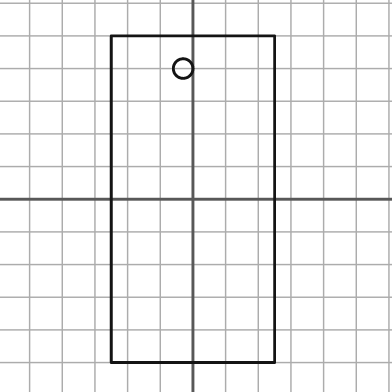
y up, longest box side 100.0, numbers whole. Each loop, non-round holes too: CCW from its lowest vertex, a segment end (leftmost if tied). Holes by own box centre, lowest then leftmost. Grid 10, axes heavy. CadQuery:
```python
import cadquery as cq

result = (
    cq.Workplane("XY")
    .moveTo(-25.0, -50.0)
    .lineTo(25.0, -50.0)
    .lineTo(25.0, 50.0)
    .lineTo(-25.0, 50.0)
    .close()
    .moveTo(-3.0, 40.0)
    .circle(3.0)
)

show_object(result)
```